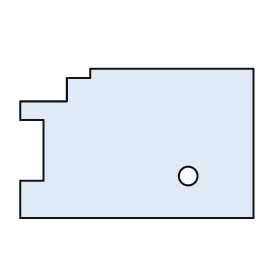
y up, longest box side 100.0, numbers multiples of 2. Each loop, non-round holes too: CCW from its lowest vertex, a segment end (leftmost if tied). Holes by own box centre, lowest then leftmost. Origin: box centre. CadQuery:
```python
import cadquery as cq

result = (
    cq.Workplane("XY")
    .moveTo(-50.0, -32.0)
    .lineTo(50.0, -32.0)
    .lineTo(50.0, 32.0)
    .lineTo(-20.0, 32.0)
    .lineTo(-20.0, 28.0)
    .lineTo(-30.0, 28.0)
    .lineTo(-30.0, 18.0)
    .lineTo(-50.0, 18.0)
    .lineTo(-50.0, 10.0)
    .lineTo(-40.0, 10.0)
    .lineTo(-40.0, -16.0)
    .lineTo(-50.0, -16.0)
    .close()
    .moveTo(22.0, -14.0)
    .circle(4.0)
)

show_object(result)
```